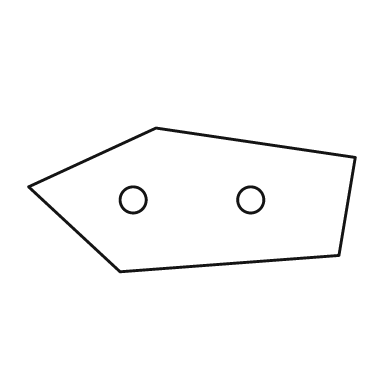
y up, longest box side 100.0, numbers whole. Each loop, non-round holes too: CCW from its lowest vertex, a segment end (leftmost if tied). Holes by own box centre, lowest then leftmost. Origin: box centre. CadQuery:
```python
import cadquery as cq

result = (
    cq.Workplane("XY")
    .moveTo(-22.0, -22.0)
    .lineTo(45.0, -17.0)
    .lineTo(50.0, 13.0)
    .lineTo(-11.0, 22.0)
    .lineTo(-50.0, 4.0)
    .close()
    .moveTo(-18.0, 0.0)
    .circle(4.0)
    .moveTo(18.0, 0.0)
    .circle(4.0)
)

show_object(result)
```